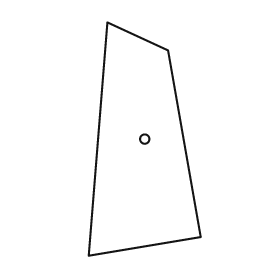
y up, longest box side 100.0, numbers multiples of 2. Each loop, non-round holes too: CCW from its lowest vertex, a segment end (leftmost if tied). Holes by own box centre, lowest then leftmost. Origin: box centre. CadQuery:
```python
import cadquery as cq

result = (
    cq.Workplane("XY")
    .moveTo(-24.0, -50.0)
    .lineTo(24.0, -42.0)
    .lineTo(10.0, 38.0)
    .lineTo(-16.0, 50.0)
    .close()
    .moveTo(0.0, 0.0)
    .circle(2.0)
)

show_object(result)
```